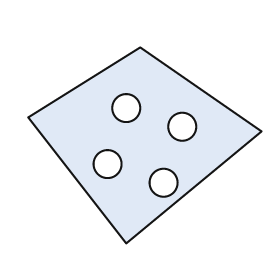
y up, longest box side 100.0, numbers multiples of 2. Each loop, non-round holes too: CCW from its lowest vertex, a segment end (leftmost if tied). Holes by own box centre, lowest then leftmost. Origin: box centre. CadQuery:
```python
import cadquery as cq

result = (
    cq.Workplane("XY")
    .moveTo(-8.0, -42.0)
    .lineTo(50.0, 6.0)
    .lineTo(-2.0, 42.0)
    .lineTo(-50.0, 12.0)
    .close()
    .moveTo(8.0, -16.0)
    .circle(6.0)
    .moveTo(-16.0, -8.0)
    .circle(6.0)
    .moveTo(16.0, 8.0)
    .circle(6.0)
    .moveTo(-8.0, 16.0)
    .circle(6.0)
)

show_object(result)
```